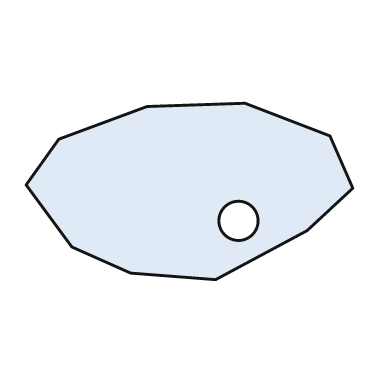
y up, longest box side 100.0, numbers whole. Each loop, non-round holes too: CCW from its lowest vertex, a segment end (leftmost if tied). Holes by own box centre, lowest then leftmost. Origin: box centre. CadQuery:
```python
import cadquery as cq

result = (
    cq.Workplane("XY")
    .moveTo(8.0, -27.0)
    .lineTo(36.0, -12.0)
    .lineTo(50.0, 1.0)
    .lineTo(43.0, 17.0)
    .lineTo(17.0, 27.0)
    .lineTo(-13.0, 26.0)
    .lineTo(-40.0, 16.0)
    .lineTo(-50.0, 2.0)
    .lineTo(-36.0, -17.0)
    .lineTo(-18.0, -25.0)
    .close()
    .moveTo(15.0, -9.0)
    .circle(6.0)
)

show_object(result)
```